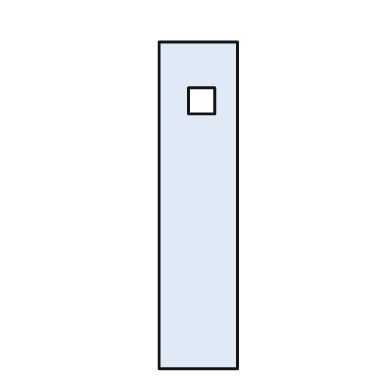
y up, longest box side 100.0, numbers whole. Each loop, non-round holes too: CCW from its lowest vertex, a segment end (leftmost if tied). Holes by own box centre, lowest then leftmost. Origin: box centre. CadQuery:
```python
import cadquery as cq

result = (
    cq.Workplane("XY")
    .moveTo(-12.0, -50.0)
    .lineTo(12.0, -50.0)
    .lineTo(12.0, 50.0)
    .lineTo(-12.0, 50.0)
    .close()
    .moveTo(-3.0, 28.0)
    .lineTo(5.0, 28.0)
    .lineTo(5.0, 36.0)
    .lineTo(-3.0, 36.0)
    .close()
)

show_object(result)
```